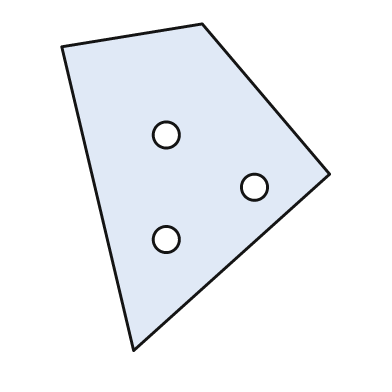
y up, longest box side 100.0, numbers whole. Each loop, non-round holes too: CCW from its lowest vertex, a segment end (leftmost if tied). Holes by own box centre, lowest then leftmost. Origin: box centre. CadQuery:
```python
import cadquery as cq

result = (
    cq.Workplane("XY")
    .moveTo(-19.0, -50.0)
    .lineTo(41.0, 4.0)
    .lineTo(2.0, 50.0)
    .lineTo(-41.0, 43.0)
    .close()
    .moveTo(-9.0, -16.0)
    .circle(4.0)
    .moveTo(18.0, 0.0)
    .circle(4.0)
    .moveTo(-9.0, 16.0)
    .circle(4.0)
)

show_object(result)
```